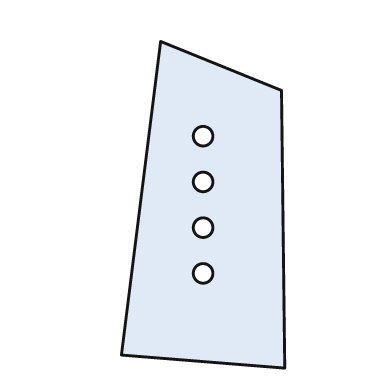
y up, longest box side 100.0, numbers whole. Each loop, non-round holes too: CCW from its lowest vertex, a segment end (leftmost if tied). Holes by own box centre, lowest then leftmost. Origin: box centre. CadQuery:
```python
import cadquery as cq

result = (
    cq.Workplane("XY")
    .moveTo(25.0, -50.0)
    .lineTo(24.0, 35.0)
    .lineTo(-13.0, 50.0)
    .lineTo(-25.0, -46.0)
    .close()
    .moveTo(0.0, -21.0)
    .circle(3.0)
    .moveTo(0.0, -7.0)
    .circle(3.0)
    .moveTo(0.0, 7.0)
    .circle(3.0)
    .moveTo(0.0, 21.0)
    .circle(3.0)
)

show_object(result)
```